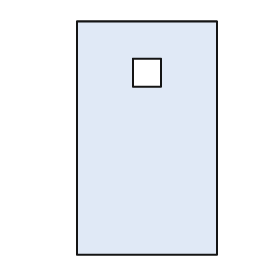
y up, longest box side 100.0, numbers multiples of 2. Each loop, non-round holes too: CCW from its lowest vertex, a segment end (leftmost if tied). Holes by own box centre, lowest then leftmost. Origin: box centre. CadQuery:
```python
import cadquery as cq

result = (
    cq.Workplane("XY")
    .moveTo(-30.0, -50.0)
    .lineTo(30.0, -50.0)
    .lineTo(30.0, 50.0)
    .lineTo(-30.0, 50.0)
    .close()
    .moveTo(-6.0, 22.0)
    .lineTo(6.0, 22.0)
    .lineTo(6.0, 34.0)
    .lineTo(-6.0, 34.0)
    .close()
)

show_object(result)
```